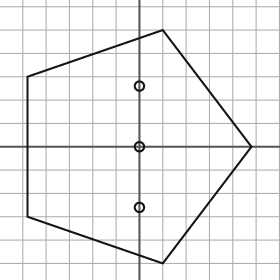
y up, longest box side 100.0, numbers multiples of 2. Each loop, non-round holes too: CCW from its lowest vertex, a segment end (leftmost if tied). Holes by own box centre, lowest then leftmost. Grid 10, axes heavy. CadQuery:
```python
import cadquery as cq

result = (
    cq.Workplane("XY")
    .moveTo(10.0, -50.0)
    .lineTo(48.0, 0.0)
    .lineTo(10.0, 50.0)
    .lineTo(-48.0, 30.0)
    .lineTo(-48.0, -30.0)
    .close()
    .moveTo(0.0, -26.0)
    .circle(2.0)
    .moveTo(0.0, 0.0)
    .circle(2.0)
    .moveTo(0.0, 26.0)
    .circle(2.0)
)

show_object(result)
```